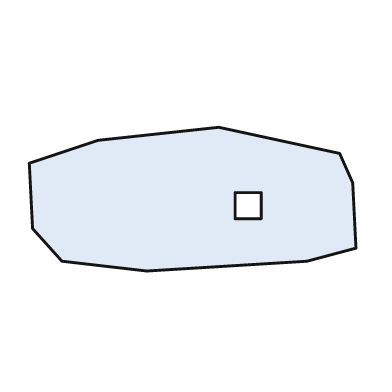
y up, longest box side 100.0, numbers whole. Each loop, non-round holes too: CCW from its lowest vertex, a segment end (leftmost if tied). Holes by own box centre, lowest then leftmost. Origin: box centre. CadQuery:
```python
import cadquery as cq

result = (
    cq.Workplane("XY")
    .moveTo(-14.0, -22.0)
    .lineTo(35.0, -19.0)
    .lineTo(50.0, -15.0)
    .lineTo(49.0, 5.0)
    .lineTo(45.0, 14.0)
    .lineTo(8.0, 22.0)
    .lineTo(-29.0, 18.0)
    .lineTo(-50.0, 11.0)
    .lineTo(-49.0, -9.0)
    .lineTo(-40.0, -19.0)
    .close()
    .moveTo(13.0, -6.0)
    .lineTo(21.0, -6.0)
    .lineTo(21.0, 2.0)
    .lineTo(13.0, 2.0)
    .close()
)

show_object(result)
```